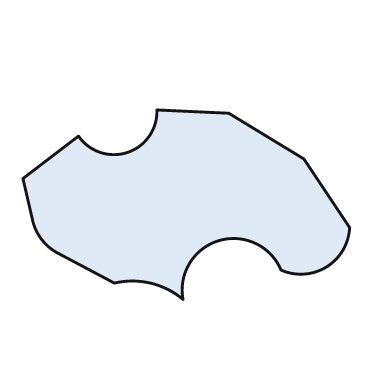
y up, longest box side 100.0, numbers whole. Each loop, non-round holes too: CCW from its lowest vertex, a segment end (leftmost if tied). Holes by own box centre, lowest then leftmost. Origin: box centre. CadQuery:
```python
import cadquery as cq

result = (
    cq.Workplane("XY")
    .moveTo(-1.0, -29.0)
    .threePointArc((10.0, -11.0), (29.0, -20.0))
    .threePointArc((43.0, -19.0), (50.0, -7.0))
    .lineTo(36.0, 14.0)
    .lineTo(13.0, 28.0)
    .lineTo(-9.0, 29.0)
    .threePointArc((-18.0, 16.0), (-33.0, 21.0))
    .lineTo(-50.0, 8.0)
    .lineTo(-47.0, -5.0)
    .threePointArc((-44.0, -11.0), (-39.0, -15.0))
    .lineTo(-22.0, -24.0)
    .threePointArc((-11.0, -24.0), (-1.0, -29.0))
    .close()
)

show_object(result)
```